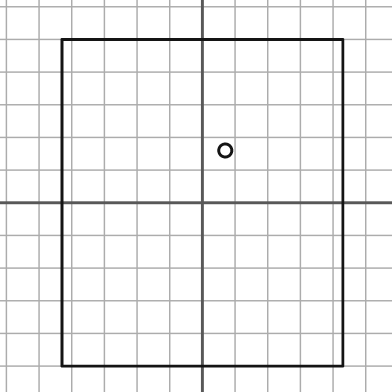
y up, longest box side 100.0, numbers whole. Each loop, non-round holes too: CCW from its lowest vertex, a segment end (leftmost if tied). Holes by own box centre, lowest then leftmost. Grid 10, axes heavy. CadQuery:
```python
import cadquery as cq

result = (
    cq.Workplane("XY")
    .moveTo(-43.0, -50.0)
    .lineTo(43.0, -50.0)
    .lineTo(43.0, 50.0)
    .lineTo(-43.0, 50.0)
    .close()
    .moveTo(7.0, 16.0)
    .circle(2.0)
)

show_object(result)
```